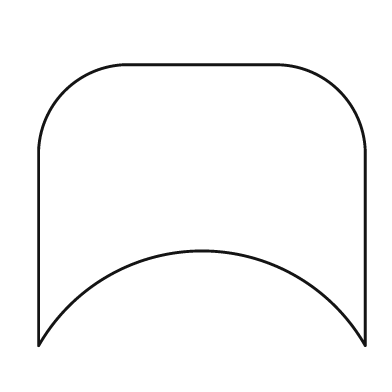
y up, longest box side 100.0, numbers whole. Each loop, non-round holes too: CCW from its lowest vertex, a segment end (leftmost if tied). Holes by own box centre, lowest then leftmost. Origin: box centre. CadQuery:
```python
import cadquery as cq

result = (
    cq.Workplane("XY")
    .moveTo(-50.0, -43.0)
    .threePointArc((0.0, -14.0), (50.0, -43.0))
    .lineTo(50.0, 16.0)
    .threePointArc((42.0, 35.0), (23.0, 43.0))
    .lineTo(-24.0, 43.0)
    .threePointArc((-42.0, 35.0), (-50.0, 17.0))
    .close()
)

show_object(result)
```